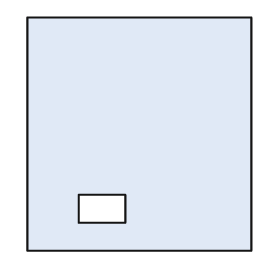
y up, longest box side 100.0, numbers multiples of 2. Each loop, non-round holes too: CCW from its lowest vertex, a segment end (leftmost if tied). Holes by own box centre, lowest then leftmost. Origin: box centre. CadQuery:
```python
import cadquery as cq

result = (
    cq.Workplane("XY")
    .moveTo(-48.0, -50.0)
    .lineTo(48.0, -50.0)
    .lineTo(48.0, 50.0)
    .lineTo(-48.0, 50.0)
    .close()
    .moveTo(-26.0, -38.0)
    .lineTo(-6.0, -38.0)
    .lineTo(-6.0, -26.0)
    .lineTo(-26.0, -26.0)
    .close()
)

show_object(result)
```